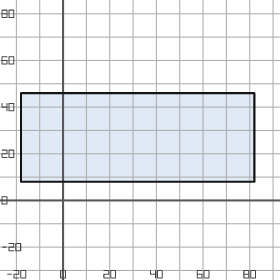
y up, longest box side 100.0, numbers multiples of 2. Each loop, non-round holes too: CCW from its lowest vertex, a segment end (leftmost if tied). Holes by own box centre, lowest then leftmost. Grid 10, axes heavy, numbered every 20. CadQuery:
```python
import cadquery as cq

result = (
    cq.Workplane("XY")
    .moveTo(-18.0, 8.0)
    .lineTo(82.0, 8.0)
    .lineTo(82.0, 46.0)
    .lineTo(-18.0, 46.0)
    .close()
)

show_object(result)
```